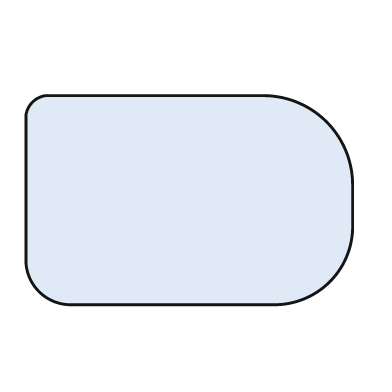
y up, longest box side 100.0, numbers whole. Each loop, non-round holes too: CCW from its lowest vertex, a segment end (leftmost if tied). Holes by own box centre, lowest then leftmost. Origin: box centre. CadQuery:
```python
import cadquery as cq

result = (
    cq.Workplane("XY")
    .moveTo(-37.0, -32.0)
    .lineTo(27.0, -32.0)
    .threePointArc((43.0, -25.0), (50.0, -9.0))
    .lineTo(50.0, 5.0)
    .threePointArc((42.0, 24.0), (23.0, 32.0))
    .lineTo(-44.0, 32.0)
    .threePointArc((-48.0, 30.0), (-50.0, 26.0))
    .lineTo(-50.0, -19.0)
    .threePointArc((-46.0, -28.0), (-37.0, -32.0))
    .close()
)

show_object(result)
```